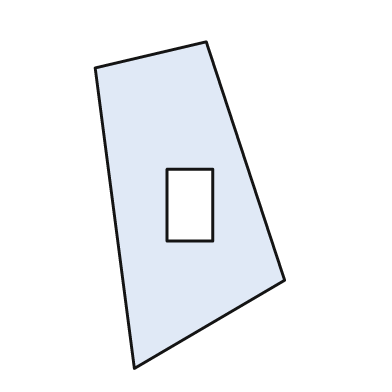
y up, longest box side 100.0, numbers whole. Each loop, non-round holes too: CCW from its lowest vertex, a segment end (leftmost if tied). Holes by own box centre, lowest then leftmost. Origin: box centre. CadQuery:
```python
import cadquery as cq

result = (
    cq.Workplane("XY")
    .moveTo(-17.0, -50.0)
    .lineTo(29.0, -23.0)
    .lineTo(5.0, 50.0)
    .lineTo(-29.0, 42.0)
    .close()
    .moveTo(-7.0, -11.0)
    .lineTo(7.0, -11.0)
    .lineTo(7.0, 11.0)
    .lineTo(-7.0, 11.0)
    .close()
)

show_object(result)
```